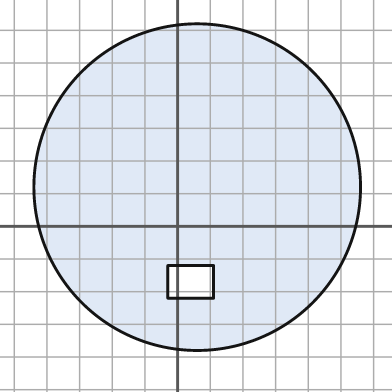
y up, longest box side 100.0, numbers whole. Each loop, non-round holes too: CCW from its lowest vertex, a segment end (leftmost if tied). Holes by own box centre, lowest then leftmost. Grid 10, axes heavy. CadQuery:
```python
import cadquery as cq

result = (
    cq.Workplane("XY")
    .moveTo(6.0, 12.0)
    .circle(50.0)
    .moveTo(-3.0, -22.0)
    .lineTo(11.0, -22.0)
    .lineTo(11.0, -12.0)
    .lineTo(-3.0, -12.0)
    .close()
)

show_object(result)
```